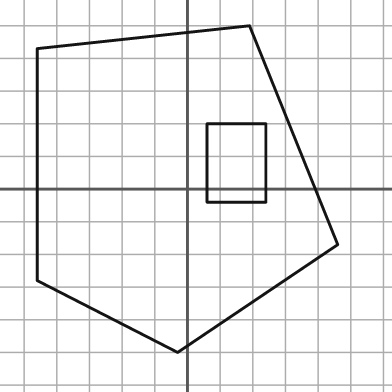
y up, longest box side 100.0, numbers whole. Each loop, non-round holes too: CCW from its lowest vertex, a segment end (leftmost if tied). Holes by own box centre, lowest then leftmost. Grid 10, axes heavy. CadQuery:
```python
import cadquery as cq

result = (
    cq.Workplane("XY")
    .moveTo(-3.0, -50.0)
    .lineTo(46.0, -17.0)
    .lineTo(19.0, 50.0)
    .lineTo(-46.0, 43.0)
    .lineTo(-46.0, -28.0)
    .close()
    .moveTo(6.0, -4.0)
    .lineTo(24.0, -4.0)
    .lineTo(24.0, 20.0)
    .lineTo(6.0, 20.0)
    .close()
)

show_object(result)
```